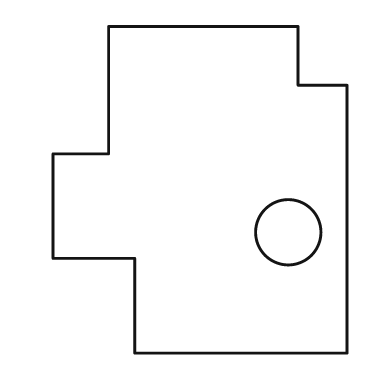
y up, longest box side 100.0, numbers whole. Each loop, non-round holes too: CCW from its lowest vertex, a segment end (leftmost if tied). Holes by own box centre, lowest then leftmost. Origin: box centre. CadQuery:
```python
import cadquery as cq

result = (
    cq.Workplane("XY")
    .moveTo(-20.0, -50.0)
    .lineTo(45.0, -50.0)
    .lineTo(45.0, 32.0)
    .lineTo(30.0, 32.0)
    .lineTo(30.0, 50.0)
    .lineTo(-28.0, 50.0)
    .lineTo(-28.0, 11.0)
    .lineTo(-45.0, 11.0)
    .lineTo(-45.0, -21.0)
    .lineTo(-20.0, -21.0)
    .close()
    .moveTo(27.0, -13.0)
    .circle(10.0)
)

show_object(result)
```